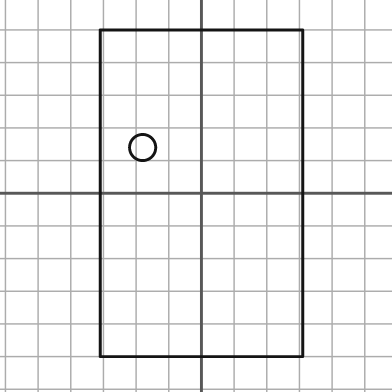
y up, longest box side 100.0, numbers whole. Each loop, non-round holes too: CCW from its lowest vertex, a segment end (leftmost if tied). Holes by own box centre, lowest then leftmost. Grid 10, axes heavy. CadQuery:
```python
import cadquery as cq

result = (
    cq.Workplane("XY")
    .moveTo(-31.0, -50.0)
    .lineTo(31.0, -50.0)
    .lineTo(31.0, 50.0)
    .lineTo(-31.0, 50.0)
    .close()
    .moveTo(-18.0, 14.0)
    .circle(4.0)
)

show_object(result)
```